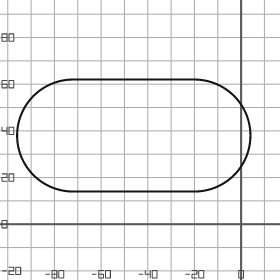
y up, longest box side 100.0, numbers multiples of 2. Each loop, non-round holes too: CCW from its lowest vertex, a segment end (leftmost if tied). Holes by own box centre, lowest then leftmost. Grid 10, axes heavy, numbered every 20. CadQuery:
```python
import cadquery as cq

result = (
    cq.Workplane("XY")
    .moveTo(-72.0, 14.0)
    .lineTo(-20.0, 14.0)
    .threePointArc((4.0, 38.0), (-20.0, 62.0))
    .lineTo(-72.0, 62.0)
    .threePointArc((-96.0, 38.0), (-72.0, 14.0))
    .close()
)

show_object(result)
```